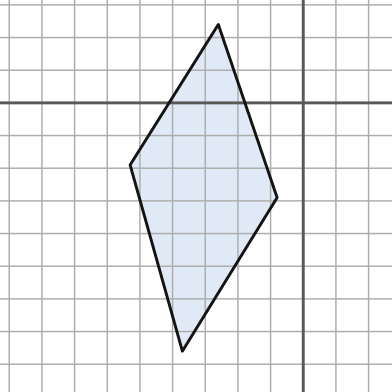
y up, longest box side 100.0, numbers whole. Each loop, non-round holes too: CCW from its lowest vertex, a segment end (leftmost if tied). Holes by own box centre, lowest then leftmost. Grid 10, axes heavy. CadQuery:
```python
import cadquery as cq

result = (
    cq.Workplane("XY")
    .moveTo(-37.0, -76.0)
    .lineTo(-8.0, -29.0)
    .lineTo(-26.0, 24.0)
    .lineTo(-53.0, -19.0)
    .close()
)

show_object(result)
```